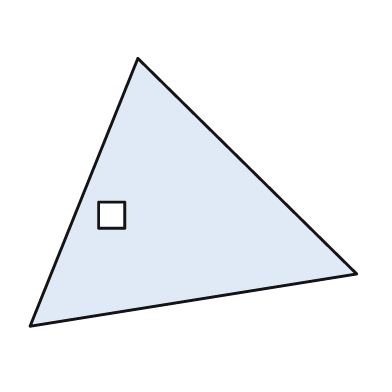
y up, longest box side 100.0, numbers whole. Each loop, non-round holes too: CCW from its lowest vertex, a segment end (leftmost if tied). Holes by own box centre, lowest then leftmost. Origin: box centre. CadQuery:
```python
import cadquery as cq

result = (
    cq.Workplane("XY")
    .moveTo(-50.0, -41.0)
    .lineTo(50.0, -25.0)
    .lineTo(-17.0, 41.0)
    .close()
    .moveTo(-29.0, -11.0)
    .lineTo(-21.0, -11.0)
    .lineTo(-21.0, -3.0)
    .lineTo(-29.0, -3.0)
    .close()
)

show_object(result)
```